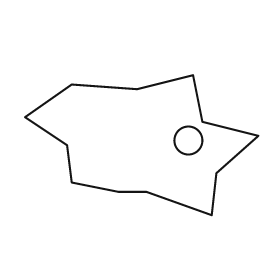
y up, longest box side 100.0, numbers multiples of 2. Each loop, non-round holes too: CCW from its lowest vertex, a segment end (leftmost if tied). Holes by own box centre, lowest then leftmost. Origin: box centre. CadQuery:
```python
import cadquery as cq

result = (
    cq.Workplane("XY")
    .moveTo(30.0, -30.0)
    .lineTo(32.0, -12.0)
    .lineTo(50.0, 4.0)
    .lineTo(26.0, 10.0)
    .lineTo(22.0, 30.0)
    .lineTo(-2.0, 24.0)
    .lineTo(-30.0, 26.0)
    .lineTo(-50.0, 12.0)
    .lineTo(-32.0, 0.0)
    .lineTo(-30.0, -16.0)
    .lineTo(-10.0, -20.0)
    .lineTo(2.0, -20.0)
    .close()
    .moveTo(20.0, 2.0)
    .circle(6.0)
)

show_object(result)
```